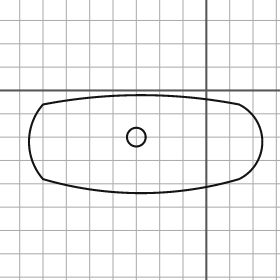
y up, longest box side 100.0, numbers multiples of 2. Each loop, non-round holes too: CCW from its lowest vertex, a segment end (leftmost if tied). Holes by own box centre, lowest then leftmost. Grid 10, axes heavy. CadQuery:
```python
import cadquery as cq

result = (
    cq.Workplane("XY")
    .moveTo(-70.0, -38.0)
    .threePointArc((-28.0, -44.0), (14.0, -38.0))
    .threePointArc((24.0, -22.0), (14.0, -6.0))
    .threePointArc((-28.0, -2.0), (-70.0, -6.0))
    .threePointArc((-76.0, -22.0), (-70.0, -38.0))
    .close()
    .moveTo(-30.0, -20.0)
    .circle(4.0)
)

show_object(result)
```